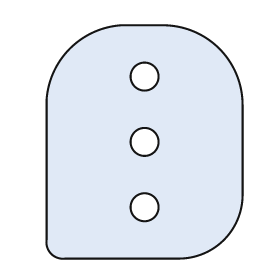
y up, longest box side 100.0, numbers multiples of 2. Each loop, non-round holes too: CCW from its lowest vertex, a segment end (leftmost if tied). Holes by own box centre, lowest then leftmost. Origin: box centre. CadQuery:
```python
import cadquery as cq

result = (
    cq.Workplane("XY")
    .moveTo(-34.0, -50.0)
    .lineTo(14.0, -50.0)
    .threePointArc((34.0, -42.0), (42.0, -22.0))
    .lineTo(42.0, 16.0)
    .threePointArc((32.0, 40.0), (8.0, 50.0))
    .lineTo(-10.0, 50.0)
    .threePointArc((-32.0, 40.0), (-42.0, 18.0))
    .lineTo(-42.0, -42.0)
    .threePointArc((-40.0, -48.0), (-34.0, -50.0))
    .close()
    .moveTo(0.0, -28.0)
    .circle(6.0)
    .moveTo(0.0, 0.0)
    .circle(6.0)
    .moveTo(0.0, 28.0)
    .circle(6.0)
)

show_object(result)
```